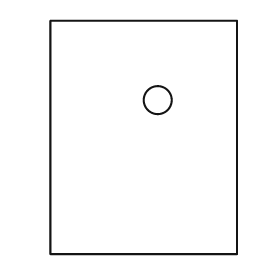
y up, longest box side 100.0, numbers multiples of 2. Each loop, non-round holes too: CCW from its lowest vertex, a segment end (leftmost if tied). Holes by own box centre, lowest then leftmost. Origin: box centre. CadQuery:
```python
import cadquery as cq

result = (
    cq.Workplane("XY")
    .moveTo(-40.0, -50.0)
    .lineTo(40.0, -50.0)
    .lineTo(40.0, 50.0)
    .lineTo(-40.0, 50.0)
    .close()
    .moveTo(6.0, 16.0)
    .circle(6.0)
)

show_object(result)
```